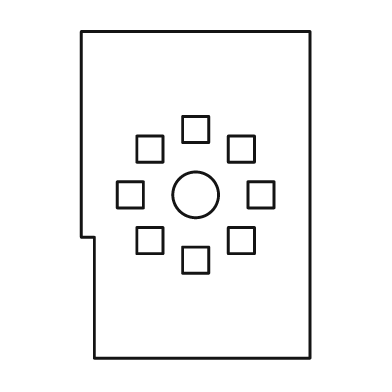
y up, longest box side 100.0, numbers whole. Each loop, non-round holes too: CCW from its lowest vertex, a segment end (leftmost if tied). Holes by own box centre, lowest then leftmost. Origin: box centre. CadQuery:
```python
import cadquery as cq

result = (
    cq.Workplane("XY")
    .moveTo(-31.0, -50.0)
    .lineTo(35.0, -50.0)
    .lineTo(35.0, 50.0)
    .lineTo(-35.0, 50.0)
    .lineTo(-35.0, -13.0)
    .lineTo(-31.0, -13.0)
    .close()
    .moveTo(-4.0, -24.0)
    .lineTo(4.0, -24.0)
    .lineTo(4.0, -16.0)
    .lineTo(-4.0, -16.0)
    .close()
    .moveTo(-18.0, -18.0)
    .lineTo(-10.0, -18.0)
    .lineTo(-10.0, -10.0)
    .lineTo(-18.0, -10.0)
    .close()
    .moveTo(10.0, -18.0)
    .lineTo(18.0, -18.0)
    .lineTo(18.0, -10.0)
    .lineTo(10.0, -10.0)
    .close()
    .moveTo(-24.0, -4.0)
    .lineTo(-16.0, -4.0)
    .lineTo(-16.0, 4.0)
    .lineTo(-24.0, 4.0)
    .close()
    .moveTo(0.0, 0.0)
    .circle(7.0)
    .moveTo(16.0, -4.0)
    .lineTo(24.0, -4.0)
    .lineTo(24.0, 4.0)
    .lineTo(16.0, 4.0)
    .close()
    .moveTo(-18.0, 10.0)
    .lineTo(-10.0, 10.0)
    .lineTo(-10.0, 18.0)
    .lineTo(-18.0, 18.0)
    .close()
    .moveTo(10.0, 10.0)
    .lineTo(18.0, 10.0)
    .lineTo(18.0, 18.0)
    .lineTo(10.0, 18.0)
    .close()
    .moveTo(-4.0, 16.0)
    .lineTo(4.0, 16.0)
    .lineTo(4.0, 24.0)
    .lineTo(-4.0, 24.0)
    .close()
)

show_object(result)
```